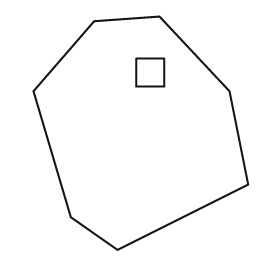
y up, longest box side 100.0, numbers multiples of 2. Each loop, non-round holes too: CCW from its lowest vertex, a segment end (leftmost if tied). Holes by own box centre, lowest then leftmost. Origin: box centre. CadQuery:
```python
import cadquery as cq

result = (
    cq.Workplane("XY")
    .moveTo(-10.0, -50.0)
    .lineTo(46.0, -22.0)
    .lineTo(38.0, 18.0)
    .lineTo(8.0, 50.0)
    .lineTo(-20.0, 48.0)
    .lineTo(-46.0, 18.0)
    .lineTo(-30.0, -36.0)
    .close()
    .moveTo(-2.0, 20.0)
    .lineTo(10.0, 20.0)
    .lineTo(10.0, 32.0)
    .lineTo(-2.0, 32.0)
    .close()
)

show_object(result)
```